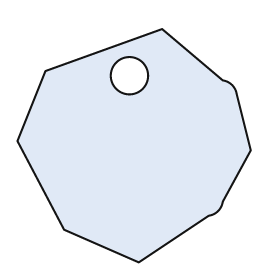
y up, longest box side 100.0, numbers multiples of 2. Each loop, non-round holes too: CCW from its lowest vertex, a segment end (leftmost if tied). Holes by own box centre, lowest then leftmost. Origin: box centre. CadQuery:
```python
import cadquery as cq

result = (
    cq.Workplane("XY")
    .moveTo(2.0, -50.0)
    .lineTo(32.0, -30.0)
    .threePointArc((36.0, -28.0), (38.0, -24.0))
    .lineTo(50.0, -2.0)
    .lineTo(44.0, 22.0)
    .threePointArc((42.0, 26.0), (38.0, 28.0))
    .lineTo(12.0, 50.0)
    .lineTo(-38.0, 32.0)
    .lineTo(-50.0, 2.0)
    .lineTo(-30.0, -36.0)
    .close()
    .moveTo(-2.0, 30.0)
    .circle(8.0)
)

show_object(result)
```